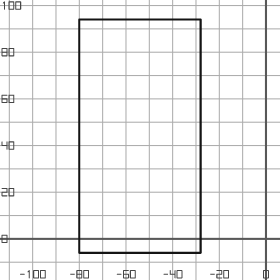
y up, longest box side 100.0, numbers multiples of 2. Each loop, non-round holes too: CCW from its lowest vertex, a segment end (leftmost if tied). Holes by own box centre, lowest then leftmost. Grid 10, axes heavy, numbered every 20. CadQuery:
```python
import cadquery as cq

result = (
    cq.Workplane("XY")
    .moveTo(-80.0, -6.0)
    .lineTo(-28.0, -6.0)
    .lineTo(-28.0, 94.0)
    .lineTo(-80.0, 94.0)
    .close()
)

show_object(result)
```